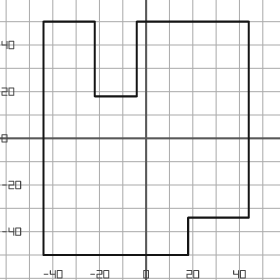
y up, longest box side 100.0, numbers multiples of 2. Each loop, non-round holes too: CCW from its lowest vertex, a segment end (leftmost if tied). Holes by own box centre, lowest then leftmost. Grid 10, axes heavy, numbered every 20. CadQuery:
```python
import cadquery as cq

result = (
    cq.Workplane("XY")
    .moveTo(-44.0, -50.0)
    .lineTo(18.0, -50.0)
    .lineTo(18.0, -34.0)
    .lineTo(44.0, -34.0)
    .lineTo(44.0, 50.0)
    .lineTo(-4.0, 50.0)
    .lineTo(-4.0, 18.0)
    .lineTo(-22.0, 18.0)
    .lineTo(-22.0, 50.0)
    .lineTo(-44.0, 50.0)
    .close()
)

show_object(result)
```